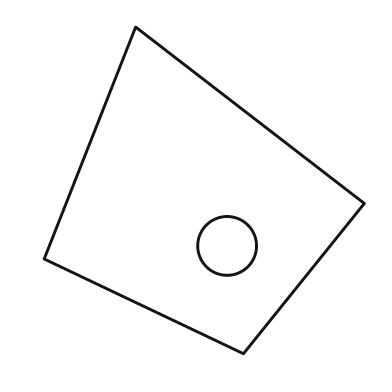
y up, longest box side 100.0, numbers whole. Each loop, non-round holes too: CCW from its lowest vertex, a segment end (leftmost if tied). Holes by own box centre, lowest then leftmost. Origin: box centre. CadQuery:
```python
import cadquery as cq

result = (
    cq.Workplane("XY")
    .moveTo(12.0, -50.0)
    .lineTo(49.0, -4.0)
    .lineTo(-21.0, 50.0)
    .lineTo(-49.0, -21.0)
    .close()
    .moveTo(7.0, -17.0)
    .circle(9.0)
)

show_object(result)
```